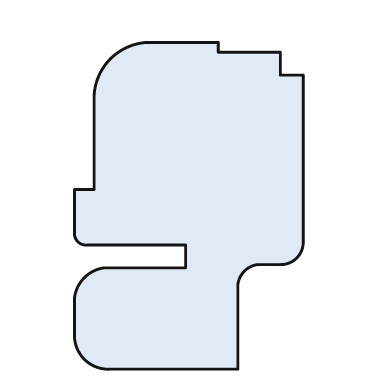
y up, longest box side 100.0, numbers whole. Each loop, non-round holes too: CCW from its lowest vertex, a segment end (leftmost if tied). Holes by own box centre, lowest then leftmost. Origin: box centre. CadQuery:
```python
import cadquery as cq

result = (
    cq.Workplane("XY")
    .moveTo(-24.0, -50.0)
    .lineTo(15.0, -50.0)
    .lineTo(15.0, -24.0)
    .threePointArc((17.0, -20.0), (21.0, -18.0))
    .lineTo(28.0, -18.0)
    .threePointArc((33.0, -16.0), (35.0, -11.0))
    .lineTo(35.0, 40.0)
    .lineTo(28.0, 40.0)
    .lineTo(28.0, 47.0)
    .lineTo(9.0, 47.0)
    .lineTo(9.0, 50.0)
    .lineTo(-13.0, 50.0)
    .threePointArc((-24.0, 45.0), (-29.0, 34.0))
    .lineTo(-29.0, 5.0)
    .lineTo(-35.0, 5.0)
    .lineTo(-35.0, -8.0)
    .threePointArc((-34.0, -11.0), (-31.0, -12.0))
    .lineTo(-1.0, -12.0)
    .lineTo(-1.0, -19.0)
    .lineTo(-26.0, -19.0)
    .threePointArc((-32.0, -22.0), (-35.0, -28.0))
    .lineTo(-35.0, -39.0)
    .threePointArc((-32.0, -47.0), (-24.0, -50.0))
    .close()
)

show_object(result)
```